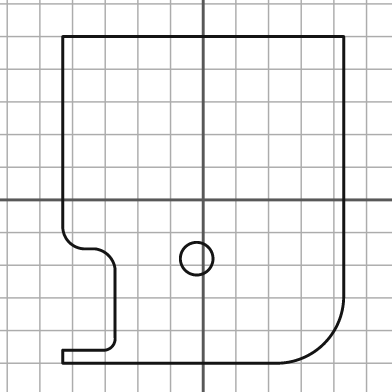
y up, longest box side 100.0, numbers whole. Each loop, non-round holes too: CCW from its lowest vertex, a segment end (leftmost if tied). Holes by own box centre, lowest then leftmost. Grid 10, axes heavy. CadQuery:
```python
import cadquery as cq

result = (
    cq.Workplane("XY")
    .moveTo(-43.0, -50.0)
    .lineTo(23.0, -50.0)
    .threePointArc((37.0, -44.0), (43.0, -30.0))
    .lineTo(43.0, 50.0)
    .lineTo(-43.0, 50.0)
    .lineTo(-43.0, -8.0)
    .threePointArc((-41.0, -13.0), (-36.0, -15.0))
    .lineTo(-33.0, -15.0)
    .threePointArc((-29.0, -17.0), (-27.0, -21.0))
    .lineTo(-27.0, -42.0)
    .threePointArc((-28.0, -45.0), (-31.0, -46.0))
    .lineTo(-43.0, -46.0)
    .close()
    .moveTo(-2.0, -18.0)
    .circle(5.0)
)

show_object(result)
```